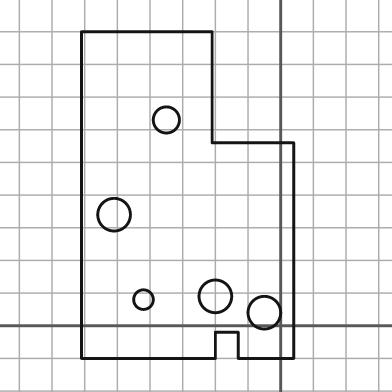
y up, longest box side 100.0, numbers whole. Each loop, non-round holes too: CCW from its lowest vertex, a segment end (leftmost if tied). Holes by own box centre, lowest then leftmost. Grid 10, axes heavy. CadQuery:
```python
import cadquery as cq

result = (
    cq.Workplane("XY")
    .moveTo(-61.0, -10.0)
    .lineTo(-20.0, -10.0)
    .lineTo(-20.0, -2.0)
    .lineTo(-13.0, -2.0)
    .lineTo(-13.0, -10.0)
    .lineTo(4.0, -10.0)
    .lineTo(4.0, 56.0)
    .lineTo(-21.0, 56.0)
    .lineTo(-21.0, 90.0)
    .lineTo(-61.0, 90.0)
    .close()
    .moveTo(-5.0, 4.0)
    .circle(5.0)
    .moveTo(-42.0, 8.0)
    .circle(3.0)
    .moveTo(-20.0, 9.0)
    .circle(5.0)
    .moveTo(-51.0, 34.0)
    .circle(5.0)
    .moveTo(-35.0, 63.0)
    .circle(4.0)
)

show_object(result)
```